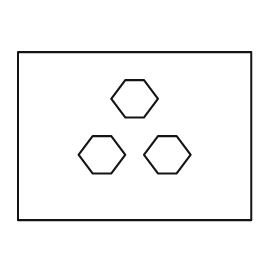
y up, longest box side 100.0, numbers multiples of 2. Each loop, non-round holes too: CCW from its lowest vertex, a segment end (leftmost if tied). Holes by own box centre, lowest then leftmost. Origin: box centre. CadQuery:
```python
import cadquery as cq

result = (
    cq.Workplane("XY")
    .moveTo(-50.0, -36.0)
    .lineTo(50.0, -36.0)
    .lineTo(50.0, 36.0)
    .lineTo(-50.0, 36.0)
    .close()
    .moveTo(-18.0, -16.0)
    .lineTo(-10.0, -16.0)
    .lineTo(-4.0, -8.0)
    .lineTo(-10.0, 0.0)
    .lineTo(-18.0, 0.0)
    .lineTo(-24.0, -8.0)
    .close()
    .moveTo(10.0, -16.0)
    .lineTo(18.0, -16.0)
    .lineTo(24.0, -8.0)
    .lineTo(18.0, 0.0)
    .lineTo(10.0, 0.0)
    .lineTo(4.0, -8.0)
    .close()
    .moveTo(-4.0, 8.0)
    .lineTo(4.0, 8.0)
    .lineTo(10.0, 16.0)
    .lineTo(4.0, 24.0)
    .lineTo(-4.0, 24.0)
    .lineTo(-10.0, 16.0)
    .close()
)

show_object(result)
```